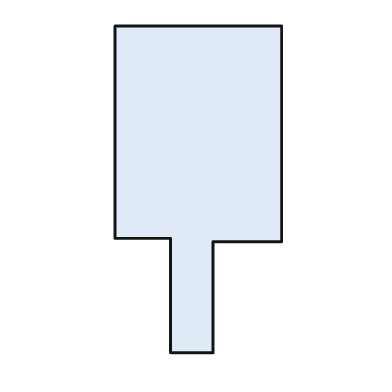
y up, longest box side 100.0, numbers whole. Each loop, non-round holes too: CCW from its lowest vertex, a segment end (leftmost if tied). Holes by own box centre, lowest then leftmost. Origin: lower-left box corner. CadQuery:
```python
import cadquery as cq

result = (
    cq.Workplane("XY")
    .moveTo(17.0, 0.0)
    .lineTo(30.0, 0.0)
    .lineTo(30.0, 34.0)
    .lineTo(51.0, 34.0)
    .lineTo(51.0, 100.0)
    .lineTo(0.0, 100.0)
    .lineTo(0.0, 35.0)
    .lineTo(17.0, 35.0)
    .close()
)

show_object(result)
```